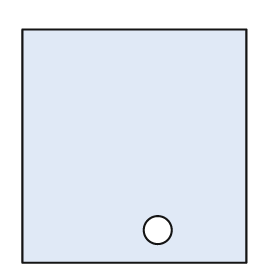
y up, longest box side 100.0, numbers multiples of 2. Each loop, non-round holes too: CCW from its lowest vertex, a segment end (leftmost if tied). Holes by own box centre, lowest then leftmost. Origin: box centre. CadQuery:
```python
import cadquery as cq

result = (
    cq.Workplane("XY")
    .moveTo(-48.0, -50.0)
    .lineTo(48.0, -50.0)
    .lineTo(48.0, 50.0)
    .lineTo(-48.0, 50.0)
    .close()
    .moveTo(10.0, -36.0)
    .circle(6.0)
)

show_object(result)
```